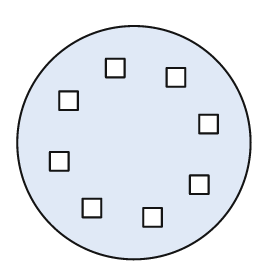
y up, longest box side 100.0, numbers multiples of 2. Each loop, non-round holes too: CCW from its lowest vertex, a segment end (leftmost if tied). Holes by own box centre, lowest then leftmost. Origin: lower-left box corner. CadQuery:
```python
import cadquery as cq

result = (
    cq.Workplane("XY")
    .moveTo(50.0, 50.0)
    .circle(50.0)
    .moveTo(54.0, 14.0)
    .lineTo(62.0, 14.0)
    .lineTo(62.0, 22.0)
    .lineTo(54.0, 22.0)
    .close()
    .moveTo(28.0, 18.0)
    .lineTo(36.0, 18.0)
    .lineTo(36.0, 26.0)
    .lineTo(28.0, 26.0)
    .close()
    .moveTo(74.0, 28.0)
    .lineTo(82.0, 28.0)
    .lineTo(82.0, 36.0)
    .lineTo(74.0, 36.0)
    .close()
    .moveTo(14.0, 38.0)
    .lineTo(22.0, 38.0)
    .lineTo(22.0, 46.0)
    .lineTo(14.0, 46.0)
    .close()
    .moveTo(78.0, 54.0)
    .lineTo(86.0, 54.0)
    .lineTo(86.0, 62.0)
    .lineTo(78.0, 62.0)
    .close()
    .moveTo(18.0, 64.0)
    .lineTo(26.0, 64.0)
    .lineTo(26.0, 72.0)
    .lineTo(18.0, 72.0)
    .close()
    .moveTo(64.0, 74.0)
    .lineTo(72.0, 74.0)
    .lineTo(72.0, 82.0)
    .lineTo(64.0, 82.0)
    .close()
    .moveTo(38.0, 78.0)
    .lineTo(46.0, 78.0)
    .lineTo(46.0, 86.0)
    .lineTo(38.0, 86.0)
    .close()
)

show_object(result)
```